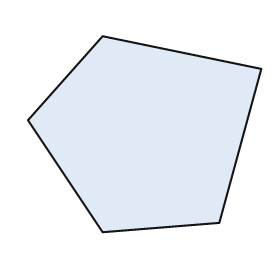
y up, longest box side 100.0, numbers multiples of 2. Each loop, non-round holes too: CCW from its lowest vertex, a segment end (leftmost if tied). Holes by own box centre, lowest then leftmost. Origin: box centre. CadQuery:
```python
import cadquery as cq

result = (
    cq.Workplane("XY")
    .moveTo(-18.0, -42.0)
    .lineTo(32.0, -38.0)
    .lineTo(50.0, 28.0)
    .lineTo(-18.0, 42.0)
    .lineTo(-50.0, 6.0)
    .close()
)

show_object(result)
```